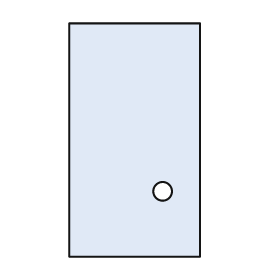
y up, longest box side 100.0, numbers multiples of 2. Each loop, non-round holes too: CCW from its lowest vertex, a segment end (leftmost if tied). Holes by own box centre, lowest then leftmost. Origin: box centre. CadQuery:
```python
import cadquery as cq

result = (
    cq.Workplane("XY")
    .moveTo(-28.0, -50.0)
    .lineTo(28.0, -50.0)
    .lineTo(28.0, 50.0)
    .lineTo(-28.0, 50.0)
    .close()
    .moveTo(12.0, -22.0)
    .circle(4.0)
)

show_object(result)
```